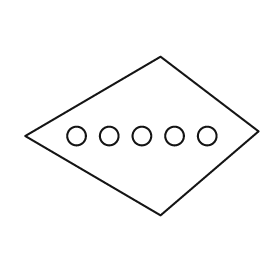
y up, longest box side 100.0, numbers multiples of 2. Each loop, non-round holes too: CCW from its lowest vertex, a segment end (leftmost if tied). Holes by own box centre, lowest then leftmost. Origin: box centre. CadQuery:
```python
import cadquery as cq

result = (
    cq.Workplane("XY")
    .moveTo(8.0, -34.0)
    .lineTo(50.0, 2.0)
    .lineTo(8.0, 34.0)
    .lineTo(-50.0, 0.0)
    .close()
    .moveTo(-28.0, 0.0)
    .circle(4.0)
    .moveTo(-14.0, 0.0)
    .circle(4.0)
    .moveTo(0.0, 0.0)
    .circle(4.0)
    .moveTo(14.0, 0.0)
    .circle(4.0)
    .moveTo(28.0, 0.0)
    .circle(4.0)
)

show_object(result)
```